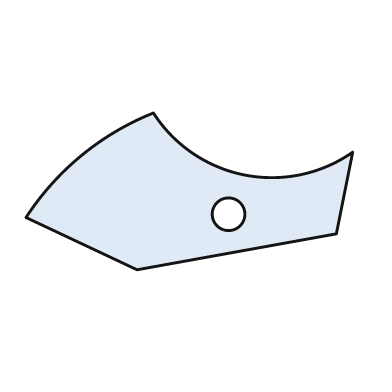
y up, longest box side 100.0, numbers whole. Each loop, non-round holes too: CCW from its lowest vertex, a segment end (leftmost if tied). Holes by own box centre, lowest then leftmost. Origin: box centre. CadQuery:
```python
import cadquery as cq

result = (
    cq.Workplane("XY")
    .moveTo(-16.0, -24.0)
    .lineTo(45.0, -13.0)
    .lineTo(50.0, 12.0)
    .threePointArc((17.0, 5.0), (-11.0, 24.0))
    .threePointArc((-33.0, 11.0), (-50.0, -8.0))
    .close()
    .moveTo(12.0, -7.0)
    .circle(5.0)
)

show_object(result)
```